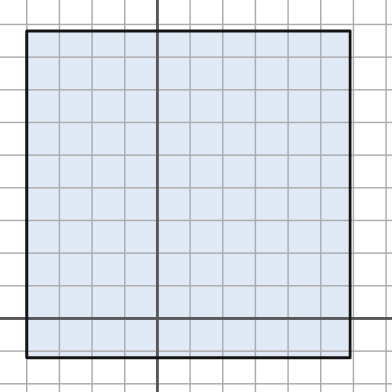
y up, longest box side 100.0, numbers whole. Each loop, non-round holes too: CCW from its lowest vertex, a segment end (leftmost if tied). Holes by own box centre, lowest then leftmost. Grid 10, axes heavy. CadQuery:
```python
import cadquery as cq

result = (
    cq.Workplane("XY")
    .moveTo(-40.0, -12.0)
    .lineTo(59.0, -12.0)
    .lineTo(59.0, 88.0)
    .lineTo(-40.0, 88.0)
    .close()
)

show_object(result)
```